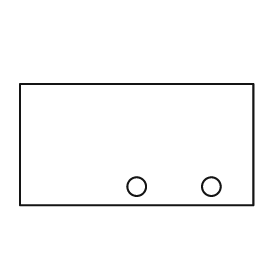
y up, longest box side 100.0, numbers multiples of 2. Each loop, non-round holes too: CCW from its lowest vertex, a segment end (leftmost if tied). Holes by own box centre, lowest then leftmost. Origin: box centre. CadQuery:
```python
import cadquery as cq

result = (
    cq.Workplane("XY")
    .moveTo(-50.0, -26.0)
    .lineTo(50.0, -26.0)
    .lineTo(50.0, 26.0)
    .lineTo(-50.0, 26.0)
    .close()
    .moveTo(0.0, -18.0)
    .circle(4.0)
    .moveTo(32.0, -18.0)
    .circle(4.0)
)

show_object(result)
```